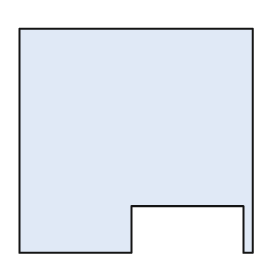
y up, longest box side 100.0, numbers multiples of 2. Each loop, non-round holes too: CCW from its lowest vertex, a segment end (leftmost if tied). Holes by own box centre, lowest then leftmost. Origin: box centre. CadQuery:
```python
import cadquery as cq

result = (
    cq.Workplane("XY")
    .moveTo(-50.0, -48.0)
    .lineTo(-2.0, -48.0)
    .lineTo(-2.0, -28.0)
    .lineTo(46.0, -28.0)
    .lineTo(46.0, -48.0)
    .lineTo(50.0, -48.0)
    .lineTo(50.0, 48.0)
    .lineTo(-50.0, 48.0)
    .close()
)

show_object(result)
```